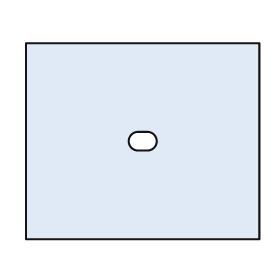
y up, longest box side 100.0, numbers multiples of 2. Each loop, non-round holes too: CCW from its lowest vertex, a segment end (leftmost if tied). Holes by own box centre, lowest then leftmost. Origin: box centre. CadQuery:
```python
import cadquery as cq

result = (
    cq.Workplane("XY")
    .moveTo(-50.0, -42.0)
    .lineTo(50.0, -42.0)
    .lineTo(50.0, 42.0)
    .lineTo(-50.0, 42.0)
    .close()
    .moveTo(-2.0, -4.0)
    .lineTo(2.0, -4.0)
    .threePointArc((6.0, 0.0), (2.0, 4.0))
    .lineTo(-2.0, 4.0)
    .threePointArc((-6.0, 0.0), (-2.0, -4.0))
    .close()
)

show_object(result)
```